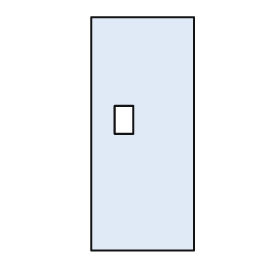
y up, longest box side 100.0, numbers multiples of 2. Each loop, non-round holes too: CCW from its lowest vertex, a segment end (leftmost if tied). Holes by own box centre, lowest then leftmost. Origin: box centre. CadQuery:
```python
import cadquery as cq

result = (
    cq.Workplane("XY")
    .moveTo(-22.0, -50.0)
    .lineTo(22.0, -50.0)
    .lineTo(22.0, 50.0)
    .lineTo(-22.0, 50.0)
    .close()
    .moveTo(-12.0, 0.0)
    .lineTo(-4.0, 0.0)
    .lineTo(-4.0, 12.0)
    .lineTo(-12.0, 12.0)
    .close()
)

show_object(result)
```